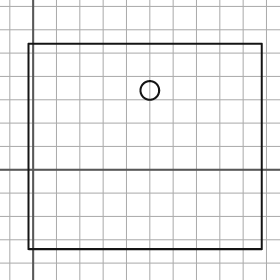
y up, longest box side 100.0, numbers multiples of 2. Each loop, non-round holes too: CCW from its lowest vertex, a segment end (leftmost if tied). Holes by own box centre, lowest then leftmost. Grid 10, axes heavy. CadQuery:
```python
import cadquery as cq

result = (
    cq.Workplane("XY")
    .moveTo(-2.0, -34.0)
    .lineTo(98.0, -34.0)
    .lineTo(98.0, 54.0)
    .lineTo(-2.0, 54.0)
    .close()
    .moveTo(50.0, 34.0)
    .circle(4.0)
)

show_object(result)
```